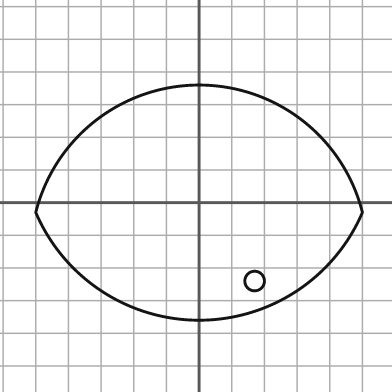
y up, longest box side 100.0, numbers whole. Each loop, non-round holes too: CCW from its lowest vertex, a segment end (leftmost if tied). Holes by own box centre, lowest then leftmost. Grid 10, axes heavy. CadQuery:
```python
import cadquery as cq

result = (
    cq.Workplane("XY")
    .moveTo(-50.0, -3.0)
    .threePointArc((0.0, -36.0), (50.0, -3.0))
    .threePointArc((0.0, 36.0), (-50.0, -3.0))
    .close()
    .moveTo(17.0, -24.0)
    .circle(3.0)
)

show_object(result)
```